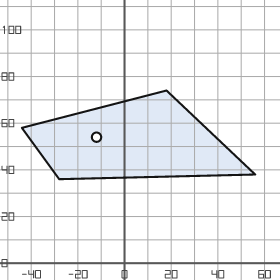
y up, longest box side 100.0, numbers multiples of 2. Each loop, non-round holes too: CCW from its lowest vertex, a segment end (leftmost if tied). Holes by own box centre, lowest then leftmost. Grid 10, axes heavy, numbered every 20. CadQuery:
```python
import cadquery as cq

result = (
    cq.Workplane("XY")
    .moveTo(-28.0, 36.0)
    .lineTo(56.0, 38.0)
    .lineTo(18.0, 74.0)
    .lineTo(-44.0, 58.0)
    .close()
    .moveTo(-12.0, 54.0)
    .circle(2.0)
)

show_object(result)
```